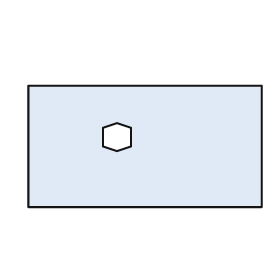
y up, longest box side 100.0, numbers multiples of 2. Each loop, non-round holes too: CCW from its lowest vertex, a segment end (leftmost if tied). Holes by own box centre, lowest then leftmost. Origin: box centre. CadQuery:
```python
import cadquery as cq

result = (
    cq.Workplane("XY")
    .moveTo(-50.0, -26.0)
    .lineTo(50.0, -26.0)
    .lineTo(50.0, 26.0)
    .lineTo(-50.0, 26.0)
    .close()
    .moveTo(-12.0, -2.0)
    .lineTo(-6.0, 0.0)
    .lineTo(-6.0, 8.0)
    .lineTo(-12.0, 10.0)
    .lineTo(-18.0, 8.0)
    .lineTo(-18.0, 0.0)
    .close()
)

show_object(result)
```